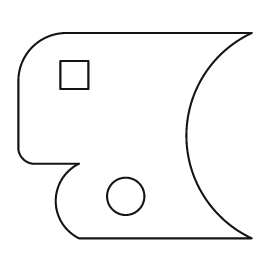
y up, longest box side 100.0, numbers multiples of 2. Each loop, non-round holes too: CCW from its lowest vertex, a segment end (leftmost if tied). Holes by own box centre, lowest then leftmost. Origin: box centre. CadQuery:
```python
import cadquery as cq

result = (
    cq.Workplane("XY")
    .moveTo(-24.0, -44.0)
    .lineTo(50.0, -44.0)
    .threePointArc((22.0, 0.0), (50.0, 44.0))
    .lineTo(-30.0, 44.0)
    .threePointArc((-44.0, 38.0), (-50.0, 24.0))
    .lineTo(-50.0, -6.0)
    .threePointArc((-48.0, -10.0), (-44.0, -12.0))
    .lineTo(-24.0, -12.0)
    .threePointArc((-34.0, -28.0), (-24.0, -44.0))
    .close()
    .moveTo(-4.0, -26.0)
    .circle(8.0)
    .moveTo(-32.0, 20.0)
    .lineTo(-20.0, 20.0)
    .lineTo(-20.0, 32.0)
    .lineTo(-32.0, 32.0)
    .close()
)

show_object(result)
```